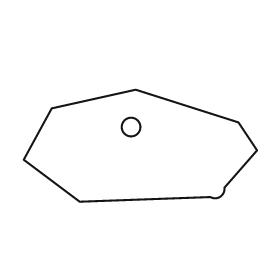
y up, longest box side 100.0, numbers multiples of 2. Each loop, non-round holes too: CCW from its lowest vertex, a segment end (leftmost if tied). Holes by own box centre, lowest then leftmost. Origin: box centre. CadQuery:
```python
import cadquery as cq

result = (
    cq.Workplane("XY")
    .moveTo(-26.0, -24.0)
    .lineTo(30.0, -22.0)
    .threePointArc((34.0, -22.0), (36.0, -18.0))
    .lineTo(50.0, -2.0)
    .lineTo(42.0, 10.0)
    .lineTo(-2.0, 24.0)
    .lineTo(-38.0, 16.0)
    .lineTo(-50.0, -6.0)
    .close()
    .moveTo(-4.0, 8.0)
    .circle(4.0)
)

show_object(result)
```